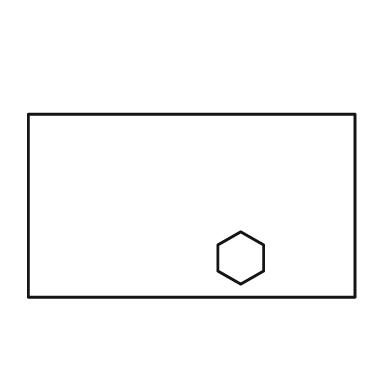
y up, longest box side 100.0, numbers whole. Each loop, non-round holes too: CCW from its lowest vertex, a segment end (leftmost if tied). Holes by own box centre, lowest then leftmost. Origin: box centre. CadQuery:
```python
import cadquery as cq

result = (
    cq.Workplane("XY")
    .moveTo(-50.0, -28.0)
    .lineTo(50.0, -28.0)
    .lineTo(50.0, 28.0)
    .lineTo(-50.0, 28.0)
    .close()
    .moveTo(15.0, -24.0)
    .lineTo(22.0, -20.0)
    .lineTo(22.0, -12.0)
    .lineTo(15.0, -8.0)
    .lineTo(8.0, -12.0)
    .lineTo(8.0, -20.0)
    .close()
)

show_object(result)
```